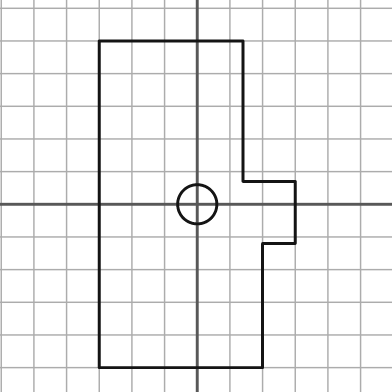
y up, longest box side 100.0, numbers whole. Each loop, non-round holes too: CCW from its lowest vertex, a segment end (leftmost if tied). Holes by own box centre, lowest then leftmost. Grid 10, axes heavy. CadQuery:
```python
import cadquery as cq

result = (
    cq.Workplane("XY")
    .moveTo(-30.0, -50.0)
    .lineTo(20.0, -50.0)
    .lineTo(20.0, -12.0)
    .lineTo(30.0, -12.0)
    .lineTo(30.0, 7.0)
    .lineTo(14.0, 7.0)
    .lineTo(14.0, 50.0)
    .lineTo(-30.0, 50.0)
    .close()
    .moveTo(0.0, 0.0)
    .circle(6.0)
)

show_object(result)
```